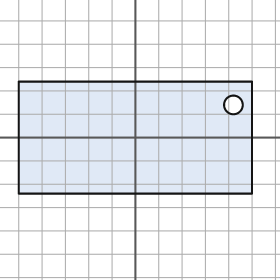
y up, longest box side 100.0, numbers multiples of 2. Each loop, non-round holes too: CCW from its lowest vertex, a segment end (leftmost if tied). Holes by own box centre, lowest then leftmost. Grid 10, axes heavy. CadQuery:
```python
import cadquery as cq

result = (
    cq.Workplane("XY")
    .moveTo(-50.0, -24.0)
    .lineTo(50.0, -24.0)
    .lineTo(50.0, 24.0)
    .lineTo(-50.0, 24.0)
    .close()
    .moveTo(42.0, 14.0)
    .circle(4.0)
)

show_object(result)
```